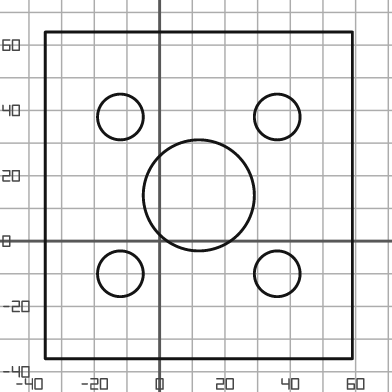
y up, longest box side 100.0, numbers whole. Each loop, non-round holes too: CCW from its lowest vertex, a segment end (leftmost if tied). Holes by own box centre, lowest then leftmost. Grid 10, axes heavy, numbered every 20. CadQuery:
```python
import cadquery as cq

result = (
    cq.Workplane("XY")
    .moveTo(-35.0, -36.0)
    .lineTo(59.0, -36.0)
    .lineTo(59.0, 64.0)
    .lineTo(-35.0, 64.0)
    .close()
    .moveTo(-12.0, -10.0)
    .circle(7.0)
    .moveTo(36.0, -10.0)
    .circle(7.0)
    .moveTo(12.0, 14.0)
    .circle(17.0)
    .moveTo(-12.0, 38.0)
    .circle(7.0)
    .moveTo(36.0, 38.0)
    .circle(7.0)
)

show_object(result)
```